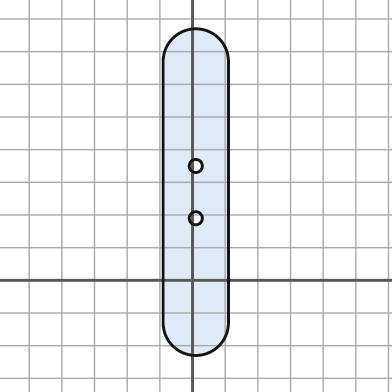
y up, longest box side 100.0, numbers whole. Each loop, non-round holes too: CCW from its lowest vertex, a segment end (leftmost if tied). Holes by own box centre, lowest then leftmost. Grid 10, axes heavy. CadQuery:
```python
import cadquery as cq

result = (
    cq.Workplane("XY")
    .moveTo(-9.0, -13.0)
    .threePointArc((1.0, -23.0), (11.0, -13.0))
    .lineTo(11.0, 67.0)
    .threePointArc((1.0, 77.0), (-9.0, 67.0))
    .close()
    .moveTo(1.0, 19.0)
    .circle(2.0)
    .moveTo(1.0, 35.0)
    .circle(2.0)
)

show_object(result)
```